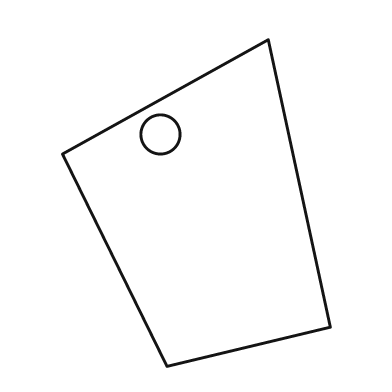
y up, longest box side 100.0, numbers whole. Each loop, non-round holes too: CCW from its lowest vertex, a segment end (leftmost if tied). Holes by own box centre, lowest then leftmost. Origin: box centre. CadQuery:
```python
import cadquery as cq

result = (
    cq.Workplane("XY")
    .moveTo(-9.0, -50.0)
    .lineTo(41.0, -38.0)
    .lineTo(22.0, 50.0)
    .lineTo(-41.0, 15.0)
    .close()
    .moveTo(-11.0, 21.0)
    .circle(6.0)
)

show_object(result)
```